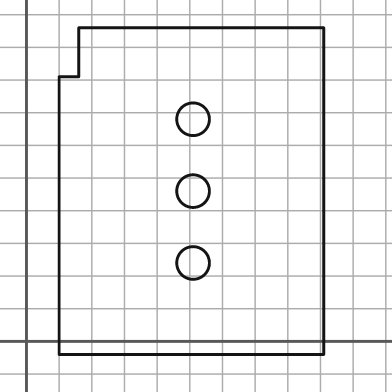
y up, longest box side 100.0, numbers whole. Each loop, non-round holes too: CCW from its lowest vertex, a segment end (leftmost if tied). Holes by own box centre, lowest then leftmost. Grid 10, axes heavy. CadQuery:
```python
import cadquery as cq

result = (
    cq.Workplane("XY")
    .moveTo(10.0, -4.0)
    .lineTo(91.0, -4.0)
    .lineTo(91.0, 96.0)
    .lineTo(16.0, 96.0)
    .lineTo(16.0, 81.0)
    .lineTo(10.0, 81.0)
    .close()
    .moveTo(51.0, 24.0)
    .circle(5.0)
    .moveTo(51.0, 46.0)
    .circle(5.0)
    .moveTo(51.0, 68.0)
    .circle(5.0)
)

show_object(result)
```